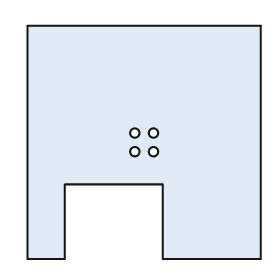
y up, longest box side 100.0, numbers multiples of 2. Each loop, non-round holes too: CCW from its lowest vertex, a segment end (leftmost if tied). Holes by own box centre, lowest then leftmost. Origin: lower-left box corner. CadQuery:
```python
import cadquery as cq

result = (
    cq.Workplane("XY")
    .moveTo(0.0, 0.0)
    .lineTo(16.0, 0.0)
    .lineTo(16.0, 32.0)
    .lineTo(58.0, 32.0)
    .lineTo(58.0, 0.0)
    .lineTo(100.0, 0.0)
    .lineTo(100.0, 100.0)
    .lineTo(0.0, 100.0)
    .close()
    .moveTo(46.0, 46.0)
    .circle(2.0)
    .moveTo(54.0, 46.0)
    .circle(2.0)
    .moveTo(46.0, 54.0)
    .circle(2.0)
    .moveTo(54.0, 54.0)
    .circle(2.0)
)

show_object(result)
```